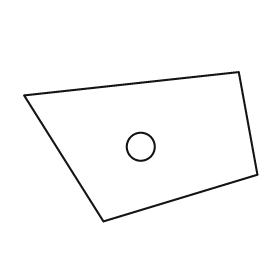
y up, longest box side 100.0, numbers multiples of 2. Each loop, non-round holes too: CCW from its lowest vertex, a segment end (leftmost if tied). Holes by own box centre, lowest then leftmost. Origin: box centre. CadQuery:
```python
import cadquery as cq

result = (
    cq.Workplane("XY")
    .moveTo(-16.0, -32.0)
    .lineTo(50.0, -12.0)
    .lineTo(42.0, 32.0)
    .lineTo(-50.0, 22.0)
    .close()
    .moveTo(0.0, 0.0)
    .circle(6.0)
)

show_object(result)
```